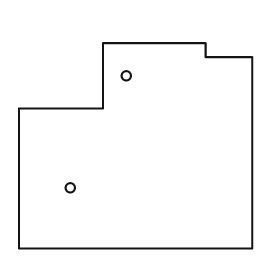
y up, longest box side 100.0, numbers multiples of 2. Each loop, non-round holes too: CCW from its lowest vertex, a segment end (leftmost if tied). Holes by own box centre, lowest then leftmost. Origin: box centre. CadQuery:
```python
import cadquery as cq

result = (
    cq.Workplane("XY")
    .moveTo(-50.0, -44.0)
    .lineTo(50.0, -44.0)
    .lineTo(50.0, 38.0)
    .lineTo(30.0, 38.0)
    .lineTo(30.0, 44.0)
    .lineTo(-14.0, 44.0)
    .lineTo(-14.0, 16.0)
    .lineTo(-50.0, 16.0)
    .close()
    .moveTo(-28.0, -18.0)
    .circle(2.0)
    .moveTo(-4.0, 30.0)
    .circle(2.0)
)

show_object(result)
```